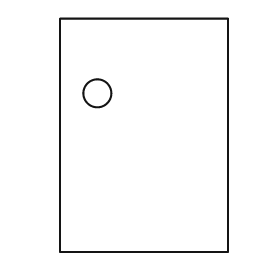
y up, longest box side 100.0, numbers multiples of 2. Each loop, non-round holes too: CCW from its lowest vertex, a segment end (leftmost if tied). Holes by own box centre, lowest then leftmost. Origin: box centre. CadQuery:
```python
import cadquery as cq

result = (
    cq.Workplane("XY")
    .moveTo(-36.0, -50.0)
    .lineTo(36.0, -50.0)
    .lineTo(36.0, 50.0)
    .lineTo(-36.0, 50.0)
    .close()
    .moveTo(-20.0, 18.0)
    .circle(6.0)
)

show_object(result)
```